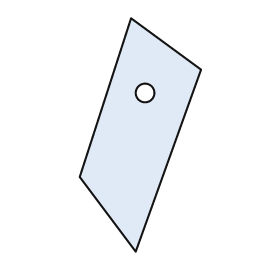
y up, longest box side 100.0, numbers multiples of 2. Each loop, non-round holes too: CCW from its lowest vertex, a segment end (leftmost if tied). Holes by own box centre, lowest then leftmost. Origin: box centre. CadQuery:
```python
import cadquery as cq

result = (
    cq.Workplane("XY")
    .moveTo(-2.0, -50.0)
    .lineTo(26.0, 28.0)
    .lineTo(-4.0, 50.0)
    .lineTo(-26.0, -18.0)
    .close()
    .moveTo(2.0, 18.0)
    .circle(4.0)
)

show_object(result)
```